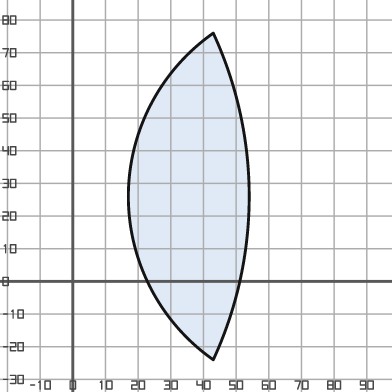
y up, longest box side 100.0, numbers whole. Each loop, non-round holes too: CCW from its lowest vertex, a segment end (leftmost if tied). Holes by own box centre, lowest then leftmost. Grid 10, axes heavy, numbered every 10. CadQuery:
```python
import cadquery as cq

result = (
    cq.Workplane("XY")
    .moveTo(43.0, -24.0)
    .threePointArc((54.0, 26.0), (43.0, 76.0))
    .threePointArc((17.0, 26.0), (43.0, -24.0))
    .close()
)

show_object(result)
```